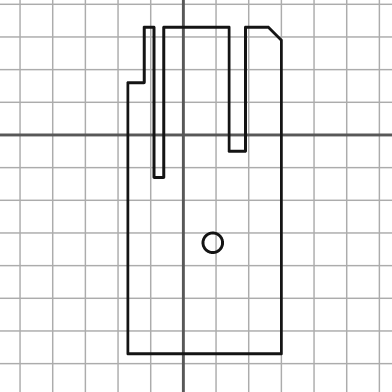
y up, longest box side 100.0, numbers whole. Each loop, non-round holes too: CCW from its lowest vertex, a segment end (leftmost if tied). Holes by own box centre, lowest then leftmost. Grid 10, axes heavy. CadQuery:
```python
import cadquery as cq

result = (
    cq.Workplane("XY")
    .moveTo(-17.0, -67.0)
    .lineTo(30.0, -67.0)
    .lineTo(30.0, 29.0)
    .lineTo(26.0, 33.0)
    .lineTo(19.0, 33.0)
    .lineTo(19.0, -5.0)
    .lineTo(14.0, -5.0)
    .lineTo(14.0, 33.0)
    .lineTo(-6.0, 33.0)
    .lineTo(-6.0, -13.0)
    .lineTo(-9.0, -13.0)
    .lineTo(-9.0, 33.0)
    .lineTo(-12.0, 33.0)
    .lineTo(-12.0, 16.0)
    .lineTo(-17.0, 16.0)
    .close()
    .moveTo(9.0, -33.0)
    .circle(3.0)
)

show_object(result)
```